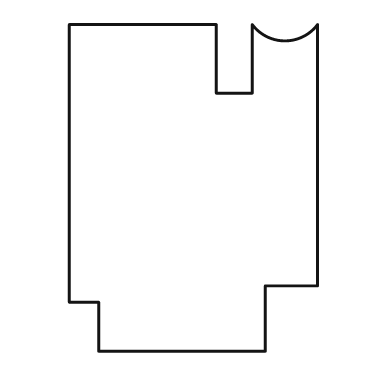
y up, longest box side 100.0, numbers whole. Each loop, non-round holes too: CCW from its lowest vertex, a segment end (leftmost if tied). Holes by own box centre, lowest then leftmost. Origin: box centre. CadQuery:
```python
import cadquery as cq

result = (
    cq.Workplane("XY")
    .moveTo(-29.0, -50.0)
    .lineTo(22.0, -50.0)
    .lineTo(22.0, -30.0)
    .lineTo(38.0, -30.0)
    .lineTo(38.0, 50.0)
    .threePointArc((28.0, 45.0), (18.0, 50.0))
    .lineTo(18.0, 29.0)
    .lineTo(7.0, 29.0)
    .lineTo(7.0, 50.0)
    .lineTo(-38.0, 50.0)
    .lineTo(-38.0, -35.0)
    .lineTo(-29.0, -35.0)
    .close()
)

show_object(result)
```